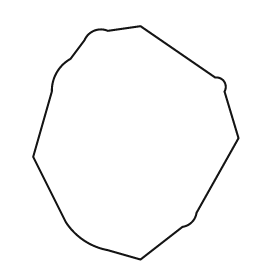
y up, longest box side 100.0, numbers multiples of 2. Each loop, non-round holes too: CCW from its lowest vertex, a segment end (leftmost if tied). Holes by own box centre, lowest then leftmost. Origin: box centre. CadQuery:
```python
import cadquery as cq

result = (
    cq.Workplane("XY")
    .moveTo(2.0, -50.0)
    .lineTo(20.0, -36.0)
    .threePointArc((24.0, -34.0), (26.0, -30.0))
    .lineTo(44.0, 2.0)
    .lineTo(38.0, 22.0)
    .threePointArc((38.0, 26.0), (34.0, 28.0))
    .lineTo(2.0, 50.0)
    .lineTo(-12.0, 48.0)
    .threePointArc((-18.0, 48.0), (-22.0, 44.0))
    .lineTo(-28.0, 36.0)
    .threePointArc((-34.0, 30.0), (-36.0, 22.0))
    .lineTo(-44.0, -6.0)
    .lineTo(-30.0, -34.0)
    .threePointArc((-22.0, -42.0), (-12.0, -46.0))
    .close()
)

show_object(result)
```